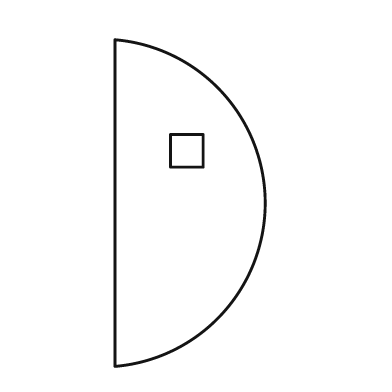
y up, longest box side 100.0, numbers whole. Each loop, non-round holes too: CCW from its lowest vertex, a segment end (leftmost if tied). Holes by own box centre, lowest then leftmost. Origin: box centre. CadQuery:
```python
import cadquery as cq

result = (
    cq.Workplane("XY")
    .moveTo(-23.0, -50.0)
    .threePointArc((23.0, 0.0), (-23.0, 50.0))
    .close()
    .moveTo(-6.0, 11.0)
    .lineTo(4.0, 11.0)
    .lineTo(4.0, 21.0)
    .lineTo(-6.0, 21.0)
    .close()
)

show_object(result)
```